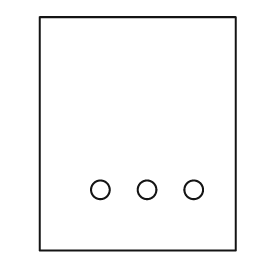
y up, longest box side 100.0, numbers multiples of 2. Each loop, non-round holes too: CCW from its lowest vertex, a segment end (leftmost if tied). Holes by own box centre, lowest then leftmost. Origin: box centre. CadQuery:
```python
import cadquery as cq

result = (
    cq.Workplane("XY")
    .moveTo(-42.0, -50.0)
    .lineTo(42.0, -50.0)
    .lineTo(42.0, 50.0)
    .lineTo(-42.0, 50.0)
    .close()
    .moveTo(-16.0, -24.0)
    .circle(4.0)
    .moveTo(4.0, -24.0)
    .circle(4.0)
    .moveTo(24.0, -24.0)
    .circle(4.0)
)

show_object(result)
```